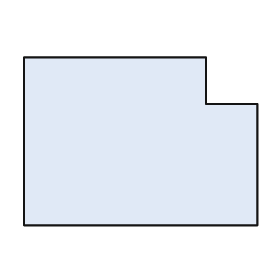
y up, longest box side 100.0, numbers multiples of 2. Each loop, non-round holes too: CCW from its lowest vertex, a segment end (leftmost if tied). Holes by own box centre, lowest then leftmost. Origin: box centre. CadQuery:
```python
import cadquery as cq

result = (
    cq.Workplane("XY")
    .moveTo(-50.0, -36.0)
    .lineTo(50.0, -36.0)
    .lineTo(50.0, 16.0)
    .lineTo(28.0, 16.0)
    .lineTo(28.0, 36.0)
    .lineTo(-50.0, 36.0)
    .close()
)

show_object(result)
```